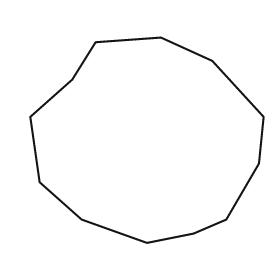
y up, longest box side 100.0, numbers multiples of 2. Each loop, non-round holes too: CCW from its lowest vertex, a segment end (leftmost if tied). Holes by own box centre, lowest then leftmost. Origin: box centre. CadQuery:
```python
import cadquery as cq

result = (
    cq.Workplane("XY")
    .moveTo(0.0, -44.0)
    .lineTo(20.0, -40.0)
    .lineTo(34.0, -34.0)
    .lineTo(48.0, -10.0)
    .lineTo(50.0, 10.0)
    .lineTo(28.0, 34.0)
    .lineTo(6.0, 44.0)
    .lineTo(-22.0, 42.0)
    .lineTo(-32.0, 26.0)
    .lineTo(-50.0, 10.0)
    .lineTo(-46.0, -18.0)
    .lineTo(-28.0, -34.0)
    .close()
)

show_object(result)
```